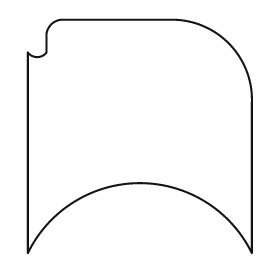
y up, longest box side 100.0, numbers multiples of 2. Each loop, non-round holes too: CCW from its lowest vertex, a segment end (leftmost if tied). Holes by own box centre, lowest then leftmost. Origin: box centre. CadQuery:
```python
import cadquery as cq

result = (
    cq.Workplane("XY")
    .moveTo(-48.0, -50.0)
    .threePointArc((0.0, -20.0), (48.0, -50.0))
    .lineTo(48.0, 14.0)
    .threePointArc((38.0, 40.0), (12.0, 50.0))
    .lineTo(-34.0, 50.0)
    .threePointArc((-38.0, 48.0), (-40.0, 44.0))
    .lineTo(-40.0, 36.0)
    .threePointArc((-44.0, 34.0), (-48.0, 36.0))
    .close()
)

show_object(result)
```